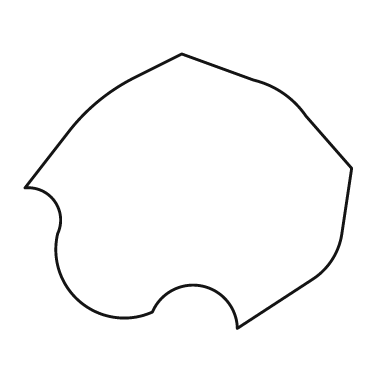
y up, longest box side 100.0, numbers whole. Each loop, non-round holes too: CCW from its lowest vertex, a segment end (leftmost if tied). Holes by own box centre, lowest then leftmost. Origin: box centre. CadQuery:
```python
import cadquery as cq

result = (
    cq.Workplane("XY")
    .moveTo(15.0, -42.0)
    .lineTo(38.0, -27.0)
    .threePointArc((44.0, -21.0), (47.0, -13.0))
    .lineTo(50.0, 7.0)
    .lineTo(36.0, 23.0)
    .threePointArc((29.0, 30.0), (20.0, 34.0))
    .lineTo(-2.0, 42.0)
    .lineTo(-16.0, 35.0)
    .threePointArc((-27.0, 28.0), (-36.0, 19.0))
    .lineTo(-50.0, 1.0)
    .threePointArc((-41.0, -3.0), (-40.0, -13.0))
    .threePointArc((-33.0, -34.0), (-11.0, -37.0))
    .threePointArc((4.0, -29.0), (15.0, -42.0))
    .close()
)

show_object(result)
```